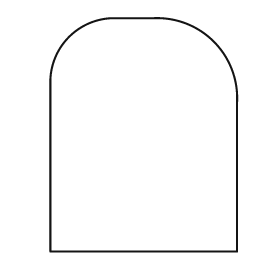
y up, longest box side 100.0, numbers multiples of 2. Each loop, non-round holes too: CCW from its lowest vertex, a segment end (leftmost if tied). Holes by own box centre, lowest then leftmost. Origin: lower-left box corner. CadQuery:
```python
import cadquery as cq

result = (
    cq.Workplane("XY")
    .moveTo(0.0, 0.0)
    .lineTo(80.0, 0.0)
    .lineTo(80.0, 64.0)
    .threePointArc((70.0, 90.0), (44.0, 100.0))
    .lineTo(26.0, 100.0)
    .threePointArc((8.0, 92.0), (0.0, 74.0))
    .close()
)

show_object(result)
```